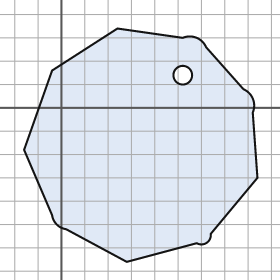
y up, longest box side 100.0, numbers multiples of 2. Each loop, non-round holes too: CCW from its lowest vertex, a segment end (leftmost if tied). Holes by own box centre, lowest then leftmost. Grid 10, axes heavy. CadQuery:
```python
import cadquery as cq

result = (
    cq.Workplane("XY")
    .moveTo(28.0, -66.0)
    .lineTo(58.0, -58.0)
    .threePointArc((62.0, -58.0), (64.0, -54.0))
    .lineTo(84.0, -30.0)
    .lineTo(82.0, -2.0)
    .threePointArc((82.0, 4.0), (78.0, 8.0))
    .lineTo(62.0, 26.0)
    .threePointArc((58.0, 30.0), (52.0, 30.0))
    .lineTo(24.0, 34.0)
    .lineTo(-4.0, 16.0)
    .lineTo(-16.0, -18.0)
    .lineTo(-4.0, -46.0)
    .threePointArc((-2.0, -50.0), (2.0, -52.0))
    .close()
    .moveTo(52.0, 14.0)
    .circle(4.0)
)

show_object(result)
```